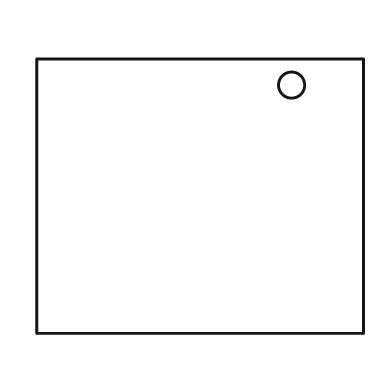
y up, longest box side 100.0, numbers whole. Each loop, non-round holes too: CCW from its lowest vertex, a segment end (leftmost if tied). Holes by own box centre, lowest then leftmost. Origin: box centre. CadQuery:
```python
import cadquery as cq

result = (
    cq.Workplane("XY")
    .moveTo(-50.0, -42.0)
    .lineTo(50.0, -42.0)
    .lineTo(50.0, 42.0)
    .lineTo(-50.0, 42.0)
    .close()
    .moveTo(28.0, 34.0)
    .circle(4.0)
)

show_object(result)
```